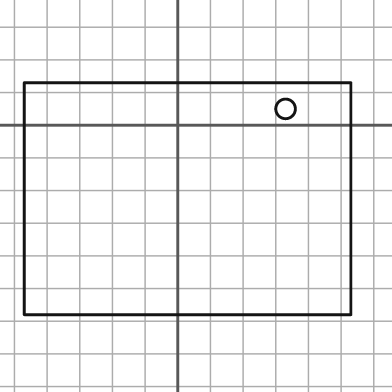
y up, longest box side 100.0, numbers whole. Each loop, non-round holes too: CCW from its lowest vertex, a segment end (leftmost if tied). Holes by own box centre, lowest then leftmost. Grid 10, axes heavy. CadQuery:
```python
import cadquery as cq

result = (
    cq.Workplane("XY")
    .moveTo(-47.0, -58.0)
    .lineTo(53.0, -58.0)
    .lineTo(53.0, 13.0)
    .lineTo(-47.0, 13.0)
    .close()
    .moveTo(33.0, 5.0)
    .circle(3.0)
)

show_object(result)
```